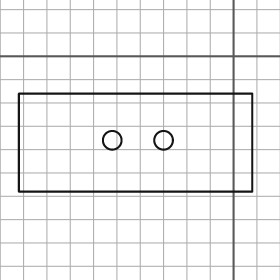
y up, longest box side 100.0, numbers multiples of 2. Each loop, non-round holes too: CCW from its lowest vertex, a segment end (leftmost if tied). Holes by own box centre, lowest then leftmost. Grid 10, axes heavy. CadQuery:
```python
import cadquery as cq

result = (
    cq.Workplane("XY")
    .moveTo(-92.0, -58.0)
    .lineTo(8.0, -58.0)
    .lineTo(8.0, -16.0)
    .lineTo(-92.0, -16.0)
    .close()
    .moveTo(-52.0, -36.0)
    .circle(4.0)
    .moveTo(-30.0, -36.0)
    .circle(4.0)
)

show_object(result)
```